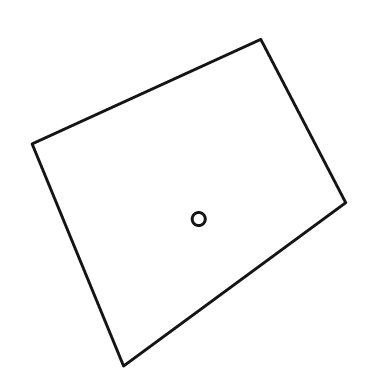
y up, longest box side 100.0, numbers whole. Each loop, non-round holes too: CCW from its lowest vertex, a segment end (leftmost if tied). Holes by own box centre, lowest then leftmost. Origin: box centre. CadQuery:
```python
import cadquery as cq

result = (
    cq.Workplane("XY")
    .moveTo(-20.0, -50.0)
    .lineTo(48.0, 0.0)
    .lineTo(22.0, 50.0)
    .lineTo(-48.0, 18.0)
    .close()
    .moveTo(3.0, -5.0)
    .circle(2.0)
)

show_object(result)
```